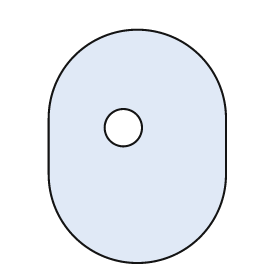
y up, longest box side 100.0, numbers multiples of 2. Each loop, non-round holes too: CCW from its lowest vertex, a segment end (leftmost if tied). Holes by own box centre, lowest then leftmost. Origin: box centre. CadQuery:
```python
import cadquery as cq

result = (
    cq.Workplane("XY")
    .moveTo(-38.0, -12.0)
    .threePointArc((0.0, -50.0), (38.0, -12.0))
    .lineTo(38.0, 12.0)
    .threePointArc((0.0, 50.0), (-38.0, 12.0))
    .close()
    .moveTo(-6.0, 8.0)
    .circle(8.0)
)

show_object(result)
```